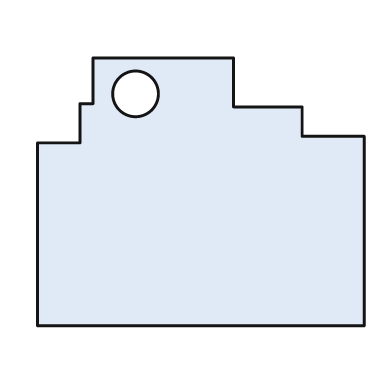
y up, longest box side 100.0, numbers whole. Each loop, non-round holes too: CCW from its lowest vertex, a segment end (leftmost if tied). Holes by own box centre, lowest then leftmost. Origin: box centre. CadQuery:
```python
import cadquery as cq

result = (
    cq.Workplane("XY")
    .moveTo(-50.0, -41.0)
    .lineTo(50.0, -41.0)
    .lineTo(50.0, 17.0)
    .lineTo(31.0, 17.0)
    .lineTo(31.0, 26.0)
    .lineTo(10.0, 26.0)
    .lineTo(10.0, 41.0)
    .lineTo(-33.0, 41.0)
    .lineTo(-33.0, 27.0)
    .lineTo(-37.0, 27.0)
    .lineTo(-37.0, 15.0)
    .lineTo(-50.0, 15.0)
    .close()
    .moveTo(-20.0, 30.0)
    .circle(7.0)
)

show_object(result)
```